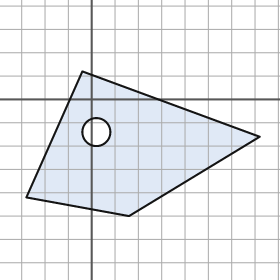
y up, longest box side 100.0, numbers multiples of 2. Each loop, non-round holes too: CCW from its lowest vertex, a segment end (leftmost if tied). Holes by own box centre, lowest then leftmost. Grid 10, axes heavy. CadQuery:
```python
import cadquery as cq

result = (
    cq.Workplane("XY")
    .moveTo(16.0, -50.0)
    .lineTo(72.0, -16.0)
    .lineTo(-4.0, 12.0)
    .lineTo(-28.0, -42.0)
    .close()
    .moveTo(2.0, -14.0)
    .circle(6.0)
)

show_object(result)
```